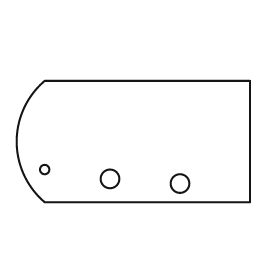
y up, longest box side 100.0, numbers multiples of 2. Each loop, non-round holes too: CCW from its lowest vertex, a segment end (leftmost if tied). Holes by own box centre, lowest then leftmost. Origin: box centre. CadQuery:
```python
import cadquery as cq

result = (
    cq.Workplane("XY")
    .moveTo(-38.0, -26.0)
    .lineTo(50.0, -26.0)
    .lineTo(50.0, 26.0)
    .lineTo(-38.0, 26.0)
    .threePointArc((-50.0, 0.0), (-38.0, -26.0))
    .close()
    .moveTo(20.0, -18.0)
    .circle(4.0)
    .moveTo(-10.0, -16.0)
    .circle(4.0)
    .moveTo(-38.0, -12.0)
    .circle(2.0)
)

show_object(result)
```